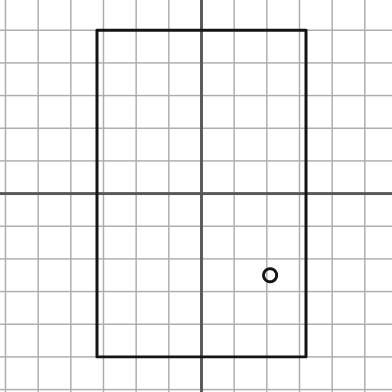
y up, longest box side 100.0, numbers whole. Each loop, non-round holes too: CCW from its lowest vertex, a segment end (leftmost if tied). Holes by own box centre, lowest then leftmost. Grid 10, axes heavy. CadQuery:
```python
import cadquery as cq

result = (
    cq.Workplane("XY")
    .moveTo(-32.0, -50.0)
    .lineTo(32.0, -50.0)
    .lineTo(32.0, 50.0)
    .lineTo(-32.0, 50.0)
    .close()
    .moveTo(21.0, -25.0)
    .circle(2.0)
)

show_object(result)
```